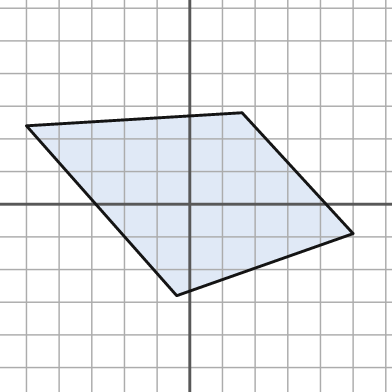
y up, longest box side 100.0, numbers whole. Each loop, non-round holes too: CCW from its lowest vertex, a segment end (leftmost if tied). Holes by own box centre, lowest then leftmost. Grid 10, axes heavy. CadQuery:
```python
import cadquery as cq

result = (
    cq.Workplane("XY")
    .moveTo(-4.0, -28.0)
    .lineTo(50.0, -9.0)
    .lineTo(16.0, 28.0)
    .lineTo(-50.0, 24.0)
    .close()
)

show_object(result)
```